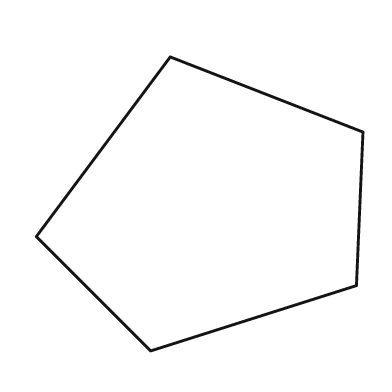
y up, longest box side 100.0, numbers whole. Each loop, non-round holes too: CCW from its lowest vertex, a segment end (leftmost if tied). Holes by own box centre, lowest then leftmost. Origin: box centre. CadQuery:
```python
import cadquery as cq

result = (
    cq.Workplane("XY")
    .moveTo(-15.0, -45.0)
    .lineTo(48.0, -25.0)
    .lineTo(50.0, 22.0)
    .lineTo(-9.0, 45.0)
    .lineTo(-50.0, -10.0)
    .close()
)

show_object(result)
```